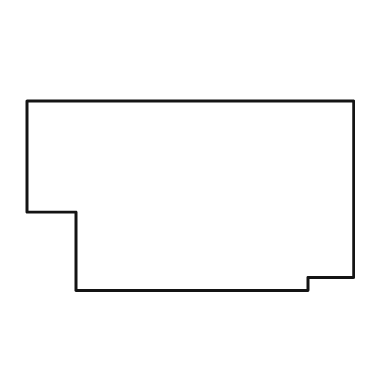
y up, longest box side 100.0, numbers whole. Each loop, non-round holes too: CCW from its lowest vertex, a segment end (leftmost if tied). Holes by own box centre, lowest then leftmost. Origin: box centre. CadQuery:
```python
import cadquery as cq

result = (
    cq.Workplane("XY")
    .moveTo(-35.0, -29.0)
    .lineTo(36.0, -29.0)
    .lineTo(36.0, -25.0)
    .lineTo(50.0, -25.0)
    .lineTo(50.0, 29.0)
    .lineTo(-50.0, 29.0)
    .lineTo(-50.0, -5.0)
    .lineTo(-35.0, -5.0)
    .close()
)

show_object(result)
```